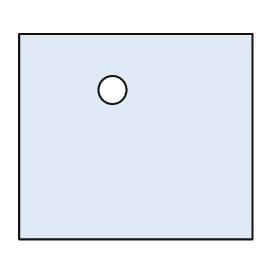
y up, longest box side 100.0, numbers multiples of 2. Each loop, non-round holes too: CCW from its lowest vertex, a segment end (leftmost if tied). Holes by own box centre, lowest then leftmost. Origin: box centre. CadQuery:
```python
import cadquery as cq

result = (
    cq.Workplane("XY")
    .moveTo(-50.0, -44.0)
    .lineTo(50.0, -44.0)
    .lineTo(50.0, 44.0)
    .lineTo(-50.0, 44.0)
    .close()
    .moveTo(-10.0, 20.0)
    .circle(6.0)
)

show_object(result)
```